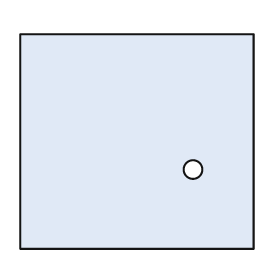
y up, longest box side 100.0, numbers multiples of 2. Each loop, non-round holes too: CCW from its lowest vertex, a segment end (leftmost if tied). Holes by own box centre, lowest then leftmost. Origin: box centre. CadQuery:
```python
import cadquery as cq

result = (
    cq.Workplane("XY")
    .moveTo(-50.0, -46.0)
    .lineTo(50.0, -46.0)
    .lineTo(50.0, 46.0)
    .lineTo(-50.0, 46.0)
    .close()
    .moveTo(24.0, -12.0)
    .circle(4.0)
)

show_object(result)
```